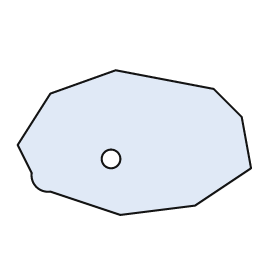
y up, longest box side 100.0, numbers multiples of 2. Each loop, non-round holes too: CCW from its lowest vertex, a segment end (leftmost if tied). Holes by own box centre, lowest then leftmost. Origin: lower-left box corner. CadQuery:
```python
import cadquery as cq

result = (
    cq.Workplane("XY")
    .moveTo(44.0, 0.0)
    .lineTo(76.0, 4.0)
    .lineTo(100.0, 20.0)
    .lineTo(96.0, 42.0)
    .lineTo(84.0, 54.0)
    .lineTo(42.0, 62.0)
    .lineTo(14.0, 52.0)
    .lineTo(0.0, 30.0)
    .lineTo(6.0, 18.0)
    .threePointArc((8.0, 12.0), (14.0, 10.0))
    .close()
    .moveTo(40.0, 24.0)
    .circle(4.0)
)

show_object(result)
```